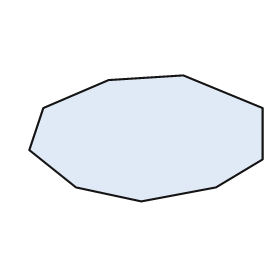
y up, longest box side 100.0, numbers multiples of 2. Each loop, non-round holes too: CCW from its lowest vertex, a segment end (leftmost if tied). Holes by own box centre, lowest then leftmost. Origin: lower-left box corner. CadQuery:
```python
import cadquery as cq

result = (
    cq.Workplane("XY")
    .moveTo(48.0, 0.0)
    .lineTo(80.0, 6.0)
    .lineTo(100.0, 18.0)
    .lineTo(100.0, 40.0)
    .lineTo(66.0, 54.0)
    .lineTo(34.0, 52.0)
    .lineTo(6.0, 40.0)
    .lineTo(0.0, 22.0)
    .lineTo(20.0, 6.0)
    .close()
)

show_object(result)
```